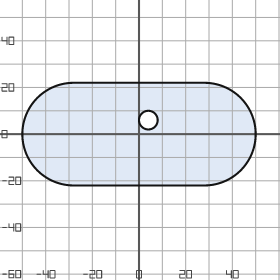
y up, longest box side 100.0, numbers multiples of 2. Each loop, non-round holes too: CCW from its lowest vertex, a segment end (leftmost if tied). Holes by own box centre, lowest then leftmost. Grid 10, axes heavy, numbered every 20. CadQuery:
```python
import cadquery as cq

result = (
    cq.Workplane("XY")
    .moveTo(-28.0, -22.0)
    .lineTo(28.0, -22.0)
    .threePointArc((50.0, 0.0), (28.0, 22.0))
    .lineTo(-28.0, 22.0)
    .threePointArc((-50.0, 0.0), (-28.0, -22.0))
    .close()
    .moveTo(4.0, 6.0)
    .circle(4.0)
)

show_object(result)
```